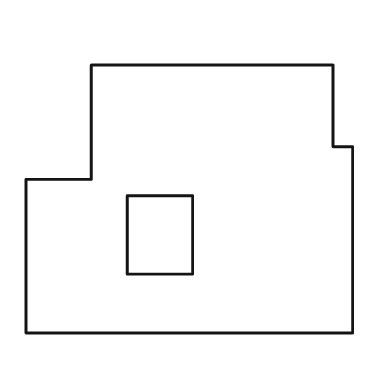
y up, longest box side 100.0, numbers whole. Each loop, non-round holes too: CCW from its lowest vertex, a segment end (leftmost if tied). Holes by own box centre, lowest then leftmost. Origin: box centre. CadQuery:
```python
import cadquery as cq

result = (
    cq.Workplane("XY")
    .moveTo(-50.0, -41.0)
    .lineTo(50.0, -41.0)
    .lineTo(50.0, 16.0)
    .lineTo(44.0, 16.0)
    .lineTo(44.0, 41.0)
    .lineTo(-30.0, 41.0)
    .lineTo(-30.0, 6.0)
    .lineTo(-50.0, 6.0)
    .close()
    .moveTo(-19.0, -23.0)
    .lineTo(1.0, -23.0)
    .lineTo(1.0, 1.0)
    .lineTo(-19.0, 1.0)
    .close()
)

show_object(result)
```